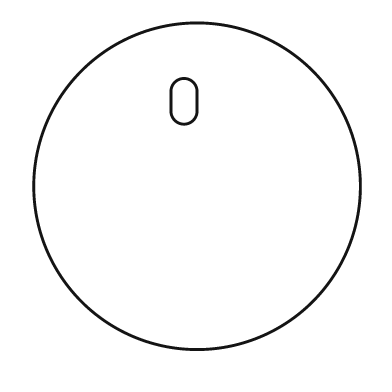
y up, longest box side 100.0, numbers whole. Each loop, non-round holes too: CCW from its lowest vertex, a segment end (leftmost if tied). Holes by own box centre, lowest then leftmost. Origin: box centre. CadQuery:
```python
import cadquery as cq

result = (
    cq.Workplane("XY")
    .moveTo(0.0, 0.0)
    .circle(50.0)
    .moveTo(-8.0, 23.0)
    .threePointArc((-4.0, 19.0), (0.0, 23.0))
    .lineTo(0.0, 29.0)
    .threePointArc((-4.0, 33.0), (-8.0, 29.0))
    .close()
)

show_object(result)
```